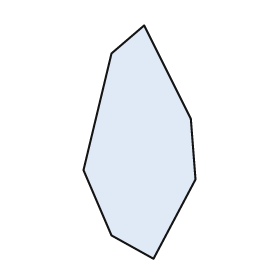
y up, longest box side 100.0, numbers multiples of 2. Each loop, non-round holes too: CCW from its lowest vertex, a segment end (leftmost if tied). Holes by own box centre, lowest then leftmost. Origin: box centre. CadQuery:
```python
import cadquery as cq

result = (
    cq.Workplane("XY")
    .moveTo(6.0, -50.0)
    .lineTo(24.0, -16.0)
    .lineTo(22.0, 10.0)
    .lineTo(2.0, 50.0)
    .lineTo(-12.0, 38.0)
    .lineTo(-24.0, -12.0)
    .lineTo(-12.0, -40.0)
    .close()
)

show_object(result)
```